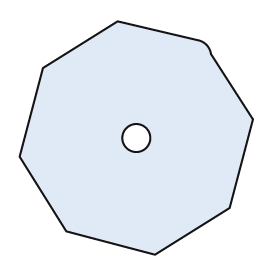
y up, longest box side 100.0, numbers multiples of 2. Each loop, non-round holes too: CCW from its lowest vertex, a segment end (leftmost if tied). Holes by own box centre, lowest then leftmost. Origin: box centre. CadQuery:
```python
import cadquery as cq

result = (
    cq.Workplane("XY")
    .moveTo(8.0, -50.0)
    .lineTo(40.0, -30.0)
    .lineTo(50.0, 8.0)
    .lineTo(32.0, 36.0)
    .threePointArc((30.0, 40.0), (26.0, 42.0))
    .lineTo(-8.0, 50.0)
    .lineTo(-40.0, 30.0)
    .lineTo(-50.0, -8.0)
    .lineTo(-30.0, -40.0)
    .close()
    .moveTo(0.0, 0.0)
    .circle(6.0)
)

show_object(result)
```